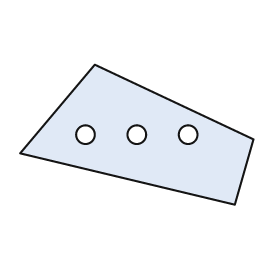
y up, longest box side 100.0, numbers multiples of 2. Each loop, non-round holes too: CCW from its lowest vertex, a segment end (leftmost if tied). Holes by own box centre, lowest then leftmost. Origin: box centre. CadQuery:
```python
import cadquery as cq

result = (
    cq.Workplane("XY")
    .moveTo(42.0, -30.0)
    .lineTo(50.0, -2.0)
    .lineTo(-18.0, 30.0)
    .lineTo(-50.0, -8.0)
    .close()
    .moveTo(-22.0, 0.0)
    .circle(4.0)
    .moveTo(0.0, 0.0)
    .circle(4.0)
    .moveTo(22.0, 0.0)
    .circle(4.0)
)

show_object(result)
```